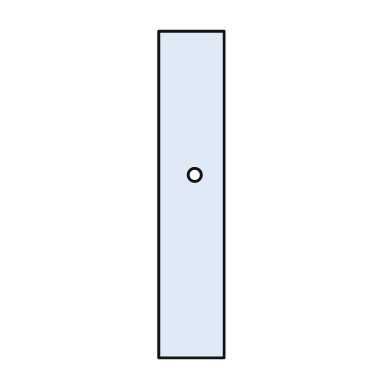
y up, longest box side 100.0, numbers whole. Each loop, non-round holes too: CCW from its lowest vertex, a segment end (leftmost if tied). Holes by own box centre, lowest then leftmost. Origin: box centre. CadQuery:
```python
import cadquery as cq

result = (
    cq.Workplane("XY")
    .moveTo(-10.0, -50.0)
    .lineTo(10.0, -50.0)
    .lineTo(10.0, 50.0)
    .lineTo(-10.0, 50.0)
    .close()
    .moveTo(1.0, 6.0)
    .circle(2.0)
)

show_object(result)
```